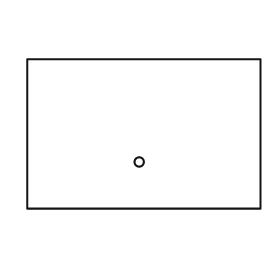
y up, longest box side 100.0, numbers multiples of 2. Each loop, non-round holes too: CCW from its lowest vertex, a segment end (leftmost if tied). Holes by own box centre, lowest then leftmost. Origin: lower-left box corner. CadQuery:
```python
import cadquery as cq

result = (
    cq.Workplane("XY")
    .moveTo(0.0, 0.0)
    .lineTo(100.0, 0.0)
    .lineTo(100.0, 64.0)
    .lineTo(0.0, 64.0)
    .close()
    .moveTo(48.0, 20.0)
    .circle(2.0)
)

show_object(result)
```